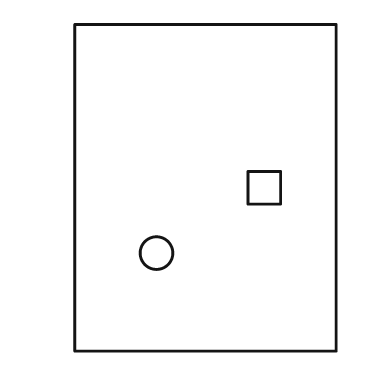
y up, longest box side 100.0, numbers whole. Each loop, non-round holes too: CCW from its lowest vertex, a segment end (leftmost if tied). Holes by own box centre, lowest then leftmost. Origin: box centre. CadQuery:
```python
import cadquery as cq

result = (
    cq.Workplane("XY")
    .moveTo(-40.0, -50.0)
    .lineTo(40.0, -50.0)
    .lineTo(40.0, 50.0)
    .lineTo(-40.0, 50.0)
    .close()
    .moveTo(-15.0, -20.0)
    .circle(5.0)
    .moveTo(13.0, -5.0)
    .lineTo(23.0, -5.0)
    .lineTo(23.0, 5.0)
    .lineTo(13.0, 5.0)
    .close()
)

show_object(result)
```